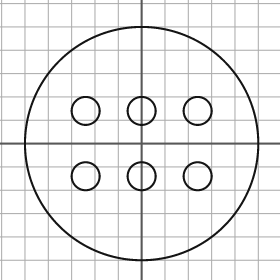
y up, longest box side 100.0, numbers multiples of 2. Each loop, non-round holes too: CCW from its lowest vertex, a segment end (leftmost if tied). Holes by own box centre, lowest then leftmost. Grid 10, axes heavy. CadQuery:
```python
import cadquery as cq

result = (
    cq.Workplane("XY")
    .moveTo(0.0, 0.0)
    .circle(50.0)
    .moveTo(-24.0, -14.0)
    .circle(6.0)
    .moveTo(0.0, -14.0)
    .circle(6.0)
    .moveTo(24.0, -14.0)
    .circle(6.0)
    .moveTo(-24.0, 14.0)
    .circle(6.0)
    .moveTo(0.0, 14.0)
    .circle(6.0)
    .moveTo(24.0, 14.0)
    .circle(6.0)
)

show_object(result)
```